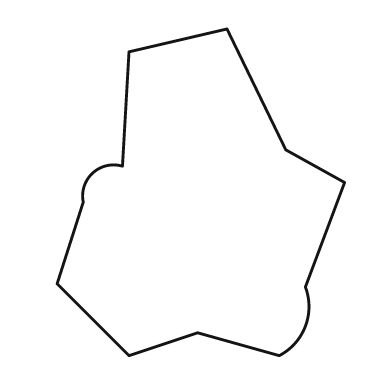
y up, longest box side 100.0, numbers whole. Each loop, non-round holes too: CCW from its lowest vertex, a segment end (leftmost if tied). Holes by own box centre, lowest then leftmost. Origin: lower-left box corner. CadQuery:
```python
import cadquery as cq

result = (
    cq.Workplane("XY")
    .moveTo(22.0, 0.0)
    .lineTo(43.0, 7.0)
    .lineTo(68.0, 0.0)
    .threePointArc((76.0, 9.0), (76.0, 21.0))
    .lineTo(88.0, 53.0)
    .lineTo(70.0, 63.0)
    .lineTo(52.0, 100.0)
    .lineTo(22.0, 93.0)
    .lineTo(20.0, 58.0)
    .threePointArc((11.0, 56.0), (8.0, 47.0))
    .lineTo(0.0, 22.0)
    .close()
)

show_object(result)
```